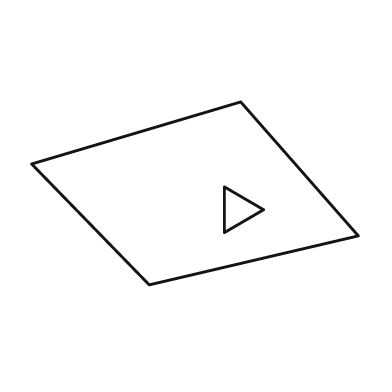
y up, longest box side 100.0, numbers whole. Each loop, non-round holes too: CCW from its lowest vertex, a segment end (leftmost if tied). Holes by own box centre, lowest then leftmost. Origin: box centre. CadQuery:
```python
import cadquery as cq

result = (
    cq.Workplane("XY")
    .moveTo(-14.0, -28.0)
    .lineTo(50.0, -13.0)
    .lineTo(14.0, 28.0)
    .lineTo(-50.0, 9.0)
    .close()
    .moveTo(9.0, -12.0)
    .lineTo(21.0, -5.0)
    .lineTo(9.0, 2.0)
    .close()
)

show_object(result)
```